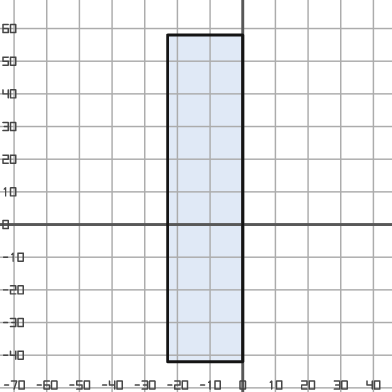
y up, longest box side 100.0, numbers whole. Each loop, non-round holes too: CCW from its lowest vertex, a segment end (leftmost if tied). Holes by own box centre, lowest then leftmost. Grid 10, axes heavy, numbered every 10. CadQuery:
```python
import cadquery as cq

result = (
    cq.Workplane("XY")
    .moveTo(-23.0, -42.0)
    .lineTo(0.0, -42.0)
    .lineTo(0.0, 58.0)
    .lineTo(-23.0, 58.0)
    .close()
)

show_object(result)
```